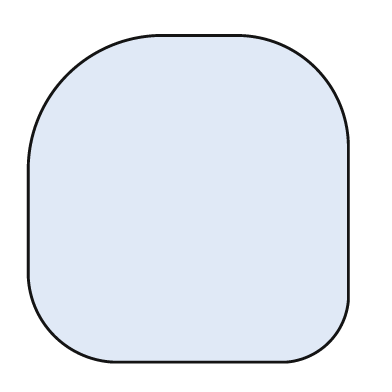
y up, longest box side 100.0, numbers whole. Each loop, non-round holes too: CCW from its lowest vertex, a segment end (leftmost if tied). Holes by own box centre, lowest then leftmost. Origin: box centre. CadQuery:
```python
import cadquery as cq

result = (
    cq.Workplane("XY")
    .moveTo(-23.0, -50.0)
    .lineTo(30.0, -50.0)
    .threePointArc((43.0, -44.0), (49.0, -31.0))
    .lineTo(49.0, 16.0)
    .threePointArc((39.0, 40.0), (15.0, 50.0))
    .lineTo(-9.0, 50.0)
    .threePointArc((-37.0, 38.0), (-49.0, 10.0))
    .lineTo(-49.0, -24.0)
    .threePointArc((-41.0, -42.0), (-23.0, -50.0))
    .close()
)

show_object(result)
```